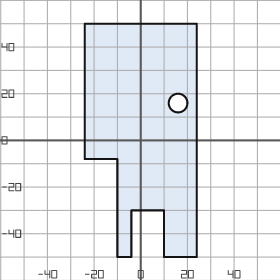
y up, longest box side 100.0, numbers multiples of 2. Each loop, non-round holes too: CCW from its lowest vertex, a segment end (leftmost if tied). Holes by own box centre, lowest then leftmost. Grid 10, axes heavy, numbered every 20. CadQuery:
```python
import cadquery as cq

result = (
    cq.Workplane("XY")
    .moveTo(-10.0, -50.0)
    .lineTo(-4.0, -50.0)
    .lineTo(-4.0, -30.0)
    .lineTo(10.0, -30.0)
    .lineTo(10.0, -50.0)
    .lineTo(24.0, -50.0)
    .lineTo(24.0, 50.0)
    .lineTo(-24.0, 50.0)
    .lineTo(-24.0, -8.0)
    .lineTo(-10.0, -8.0)
    .close()
    .moveTo(16.0, 16.0)
    .circle(4.0)
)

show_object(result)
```